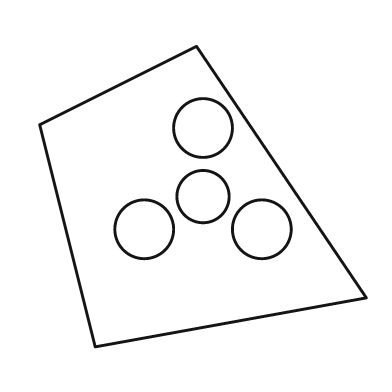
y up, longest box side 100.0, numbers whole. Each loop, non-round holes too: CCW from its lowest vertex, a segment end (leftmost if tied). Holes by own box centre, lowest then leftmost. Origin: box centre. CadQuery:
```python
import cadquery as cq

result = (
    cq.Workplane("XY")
    .moveTo(-33.0, -46.0)
    .lineTo(50.0, -31.0)
    .lineTo(-2.0, 46.0)
    .lineTo(-50.0, 22.0)
    .close()
    .moveTo(-18.0, -10.0)
    .circle(9.0)
    .moveTo(18.0, -10.0)
    .circle(9.0)
    .moveTo(0.0, 0.0)
    .circle(8.0)
    .moveTo(0.0, 21.0)
    .circle(9.0)
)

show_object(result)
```